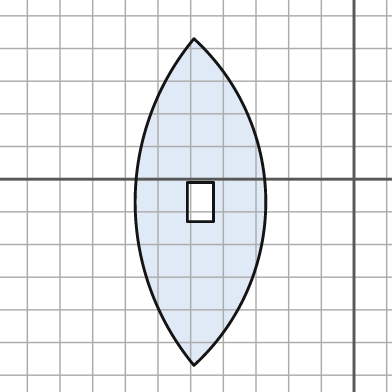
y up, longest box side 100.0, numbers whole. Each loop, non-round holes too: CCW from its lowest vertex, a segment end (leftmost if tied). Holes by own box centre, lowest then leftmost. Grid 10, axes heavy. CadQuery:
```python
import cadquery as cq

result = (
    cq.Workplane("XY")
    .moveTo(-49.0, -57.0)
    .threePointArc((-27.0, -7.0), (-49.0, 43.0))
    .threePointArc((-67.0, -7.0), (-49.0, -57.0))
    .close()
    .moveTo(-51.0, -13.0)
    .lineTo(-43.0, -13.0)
    .lineTo(-43.0, -1.0)
    .lineTo(-51.0, -1.0)
    .close()
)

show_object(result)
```